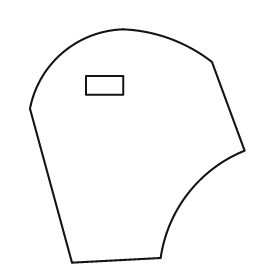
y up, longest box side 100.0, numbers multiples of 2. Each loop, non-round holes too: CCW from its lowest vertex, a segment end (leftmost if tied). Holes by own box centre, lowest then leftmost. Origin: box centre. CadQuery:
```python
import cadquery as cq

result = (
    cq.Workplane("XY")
    .moveTo(-28.0, -50.0)
    .lineTo(10.0, -48.0)
    .threePointArc((22.0, -20.0), (46.0, -2.0))
    .lineTo(32.0, 36.0)
    .threePointArc((14.0, 46.0), (-6.0, 50.0))
    .threePointArc((-32.0, 40.0), (-46.0, 16.0))
    .close()
    .moveTo(-22.0, 22.0)
    .lineTo(-6.0, 22.0)
    .lineTo(-6.0, 30.0)
    .lineTo(-22.0, 30.0)
    .close()
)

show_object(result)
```